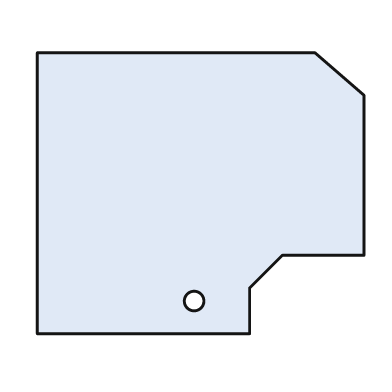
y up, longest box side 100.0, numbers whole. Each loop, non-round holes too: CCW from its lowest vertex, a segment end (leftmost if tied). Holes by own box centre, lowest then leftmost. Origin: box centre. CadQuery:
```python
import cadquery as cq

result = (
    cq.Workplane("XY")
    .moveTo(-50.0, -43.0)
    .lineTo(15.0, -43.0)
    .lineTo(15.0, -29.0)
    .lineTo(25.0, -19.0)
    .lineTo(50.0, -19.0)
    .lineTo(50.0, 30.0)
    .lineTo(35.0, 43.0)
    .lineTo(-50.0, 43.0)
    .close()
    .moveTo(-2.0, -33.0)
    .circle(3.0)
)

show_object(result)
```